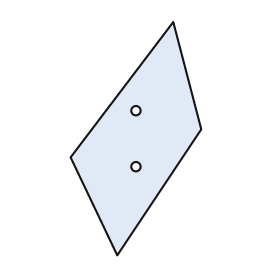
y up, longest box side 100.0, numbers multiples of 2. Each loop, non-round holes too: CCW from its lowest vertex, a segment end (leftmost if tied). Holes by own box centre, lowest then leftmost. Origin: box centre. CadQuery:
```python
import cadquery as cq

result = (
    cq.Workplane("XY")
    .moveTo(-8.0, -50.0)
    .lineTo(28.0, 4.0)
    .lineTo(16.0, 50.0)
    .lineTo(-28.0, -8.0)
    .close()
    .moveTo(0.0, -12.0)
    .circle(2.0)
    .moveTo(0.0, 12.0)
    .circle(2.0)
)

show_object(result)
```